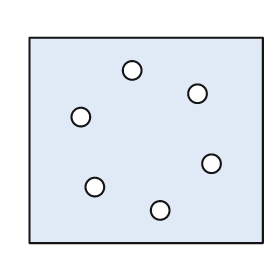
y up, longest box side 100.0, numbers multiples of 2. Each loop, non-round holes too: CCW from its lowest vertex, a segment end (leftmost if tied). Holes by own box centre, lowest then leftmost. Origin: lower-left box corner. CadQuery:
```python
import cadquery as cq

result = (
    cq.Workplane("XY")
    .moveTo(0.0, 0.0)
    .lineTo(100.0, 0.0)
    .lineTo(100.0, 88.0)
    .lineTo(0.0, 88.0)
    .close()
    .moveTo(56.0, 14.0)
    .circle(4.0)
    .moveTo(28.0, 24.0)
    .circle(4.0)
    .moveTo(78.0, 34.0)
    .circle(4.0)
    .moveTo(22.0, 54.0)
    .circle(4.0)
    .moveTo(72.0, 64.0)
    .circle(4.0)
    .moveTo(44.0, 74.0)
    .circle(4.0)
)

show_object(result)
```